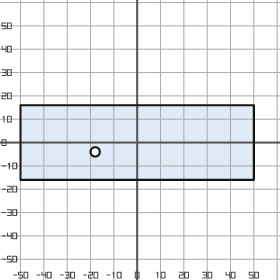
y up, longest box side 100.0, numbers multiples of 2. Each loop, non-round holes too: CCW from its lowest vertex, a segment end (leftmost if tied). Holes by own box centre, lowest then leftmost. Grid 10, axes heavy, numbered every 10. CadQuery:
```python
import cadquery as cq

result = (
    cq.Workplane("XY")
    .moveTo(-50.0, -16.0)
    .lineTo(50.0, -16.0)
    .lineTo(50.0, 16.0)
    .lineTo(-50.0, 16.0)
    .close()
    .moveTo(-18.0, -4.0)
    .circle(2.0)
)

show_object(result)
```